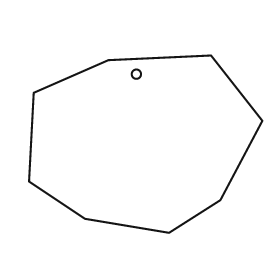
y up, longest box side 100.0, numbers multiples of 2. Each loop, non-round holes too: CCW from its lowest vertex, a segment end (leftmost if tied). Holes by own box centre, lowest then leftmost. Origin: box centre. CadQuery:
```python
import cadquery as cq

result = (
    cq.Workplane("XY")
    .moveTo(10.0, -38.0)
    .lineTo(32.0, -24.0)
    .lineTo(50.0, 10.0)
    .lineTo(28.0, 38.0)
    .lineTo(-16.0, 36.0)
    .lineTo(-48.0, 22.0)
    .lineTo(-50.0, -16.0)
    .lineTo(-26.0, -32.0)
    .close()
    .moveTo(-4.0, 30.0)
    .circle(2.0)
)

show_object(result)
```